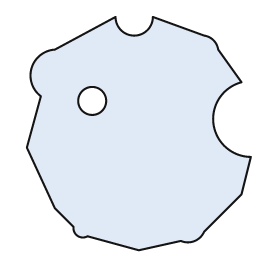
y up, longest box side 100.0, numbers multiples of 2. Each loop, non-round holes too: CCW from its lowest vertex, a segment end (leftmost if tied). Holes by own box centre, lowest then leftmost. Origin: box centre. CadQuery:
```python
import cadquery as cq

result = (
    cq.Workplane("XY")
    .moveTo(0.0, -50.0)
    .lineTo(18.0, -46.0)
    .threePointArc((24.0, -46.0), (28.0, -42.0))
    .lineTo(44.0, -26.0)
    .lineTo(48.0, -10.0)
    .threePointArc((32.0, 4.0), (44.0, 22.0))
    .lineTo(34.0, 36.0)
    .threePointArc((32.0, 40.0), (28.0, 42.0))
    .lineTo(6.0, 50.0)
    .threePointArc((-2.0, 42.0), (-10.0, 50.0))
    .lineTo(-36.0, 36.0)
    .threePointArc((-46.0, 28.0), (-42.0, 16.0))
    .lineTo(-48.0, -6.0)
    .lineTo(-36.0, -32.0)
    .lineTo(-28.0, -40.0)
    .threePointArc((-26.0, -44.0), (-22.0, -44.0))
    .close()
    .moveTo(-20.0, 14.0)
    .circle(6.0)
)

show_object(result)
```